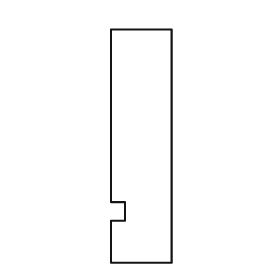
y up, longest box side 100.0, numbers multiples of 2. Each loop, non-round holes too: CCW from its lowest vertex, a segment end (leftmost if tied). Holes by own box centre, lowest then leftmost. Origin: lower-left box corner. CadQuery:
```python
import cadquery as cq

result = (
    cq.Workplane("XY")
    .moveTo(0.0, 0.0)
    .lineTo(26.0, 0.0)
    .lineTo(26.0, 100.0)
    .lineTo(0.0, 100.0)
    .lineTo(0.0, 26.0)
    .lineTo(6.0, 26.0)
    .lineTo(6.0, 18.0)
    .lineTo(0.0, 18.0)
    .close()
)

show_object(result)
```